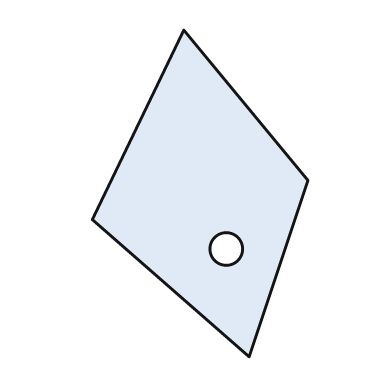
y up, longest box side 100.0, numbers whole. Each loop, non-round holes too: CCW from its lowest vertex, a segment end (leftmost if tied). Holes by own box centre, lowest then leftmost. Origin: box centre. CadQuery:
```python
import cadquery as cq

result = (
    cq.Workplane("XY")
    .moveTo(15.0, -50.0)
    .lineTo(33.0, 4.0)
    .lineTo(-5.0, 50.0)
    .lineTo(-33.0, -8.0)
    .close()
    .moveTo(8.0, -17.0)
    .circle(5.0)
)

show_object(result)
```